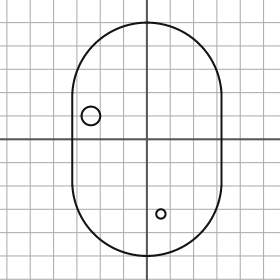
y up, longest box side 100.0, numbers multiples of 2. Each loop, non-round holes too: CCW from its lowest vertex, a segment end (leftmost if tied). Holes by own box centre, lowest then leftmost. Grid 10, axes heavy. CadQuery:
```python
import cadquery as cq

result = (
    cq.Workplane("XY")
    .moveTo(-32.0, -18.0)
    .threePointArc((0.0, -50.0), (32.0, -18.0))
    .lineTo(32.0, 18.0)
    .threePointArc((0.0, 50.0), (-32.0, 18.0))
    .close()
    .moveTo(6.0, -32.0)
    .circle(2.0)
    .moveTo(-24.0, 10.0)
    .circle(4.0)
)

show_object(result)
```